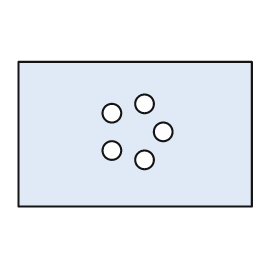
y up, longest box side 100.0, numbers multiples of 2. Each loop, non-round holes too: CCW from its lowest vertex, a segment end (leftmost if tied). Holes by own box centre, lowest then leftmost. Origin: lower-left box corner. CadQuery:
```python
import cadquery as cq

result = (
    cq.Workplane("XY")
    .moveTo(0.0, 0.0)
    .lineTo(100.0, 0.0)
    .lineTo(100.0, 62.0)
    .lineTo(0.0, 62.0)
    .close()
    .moveTo(54.0, 20.0)
    .circle(4.0)
    .moveTo(40.0, 24.0)
    .circle(4.0)
    .moveTo(62.0, 32.0)
    .circle(4.0)
    .moveTo(40.0, 40.0)
    .circle(4.0)
    .moveTo(54.0, 44.0)
    .circle(4.0)
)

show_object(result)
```